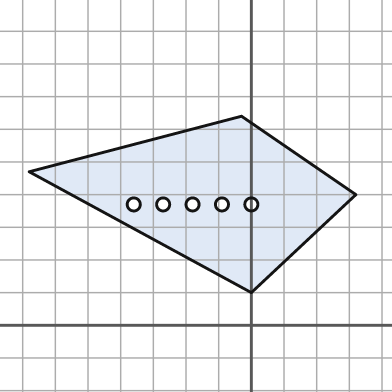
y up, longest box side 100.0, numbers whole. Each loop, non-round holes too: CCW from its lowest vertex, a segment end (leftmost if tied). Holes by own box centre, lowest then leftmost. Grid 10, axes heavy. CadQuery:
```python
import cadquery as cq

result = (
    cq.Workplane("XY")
    .moveTo(0.0, 10.0)
    .lineTo(32.0, 40.0)
    .lineTo(-3.0, 64.0)
    .lineTo(-68.0, 47.0)
    .close()
    .moveTo(-36.0, 37.0)
    .circle(2.0)
    .moveTo(-27.0, 37.0)
    .circle(2.0)
    .moveTo(-18.0, 37.0)
    .circle(2.0)
    .moveTo(-9.0, 37.0)
    .circle(2.0)
    .moveTo(0.0, 37.0)
    .circle(2.0)
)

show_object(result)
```